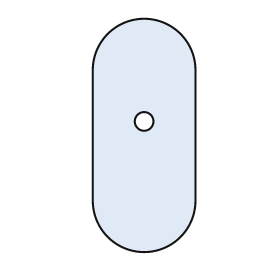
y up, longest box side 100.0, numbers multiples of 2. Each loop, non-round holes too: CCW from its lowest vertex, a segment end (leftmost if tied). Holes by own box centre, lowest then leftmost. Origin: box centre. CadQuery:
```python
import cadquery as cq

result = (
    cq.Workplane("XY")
    .moveTo(-22.0, -28.0)
    .threePointArc((0.0, -50.0), (22.0, -28.0))
    .lineTo(22.0, 28.0)
    .threePointArc((0.0, 50.0), (-22.0, 28.0))
    .close()
    .moveTo(0.0, 6.0)
    .circle(4.0)
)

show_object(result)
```